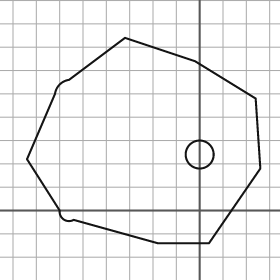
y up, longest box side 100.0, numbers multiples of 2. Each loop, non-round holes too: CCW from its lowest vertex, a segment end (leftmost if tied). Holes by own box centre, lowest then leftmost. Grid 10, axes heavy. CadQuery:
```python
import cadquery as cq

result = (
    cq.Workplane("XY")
    .moveTo(-18.0, -14.0)
    .lineTo(4.0, -14.0)
    .lineTo(26.0, 18.0)
    .lineTo(24.0, 48.0)
    .lineTo(-2.0, 64.0)
    .lineTo(-32.0, 74.0)
    .lineTo(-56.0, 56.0)
    .threePointArc((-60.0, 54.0), (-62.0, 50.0))
    .lineTo(-74.0, 22.0)
    .lineTo(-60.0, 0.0)
    .threePointArc((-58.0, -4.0), (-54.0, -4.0))
    .close()
    .moveTo(0.0, 24.0)
    .circle(6.0)
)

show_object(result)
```